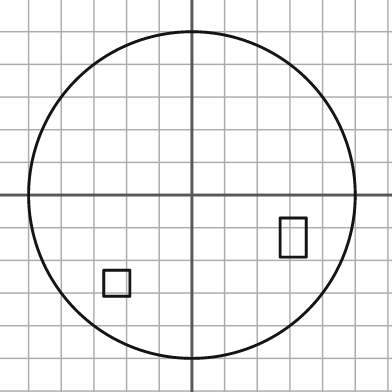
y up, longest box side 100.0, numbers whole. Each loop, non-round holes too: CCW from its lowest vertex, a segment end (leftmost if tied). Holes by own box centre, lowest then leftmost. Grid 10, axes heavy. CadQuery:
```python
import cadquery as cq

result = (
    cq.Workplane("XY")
    .moveTo(0.0, 0.0)
    .circle(50.0)
    .moveTo(-27.0, -31.0)
    .lineTo(-19.0, -31.0)
    .lineTo(-19.0, -23.0)
    .lineTo(-27.0, -23.0)
    .close()
    .moveTo(27.0, -19.0)
    .lineTo(35.0, -19.0)
    .lineTo(35.0, -7.0)
    .lineTo(27.0, -7.0)
    .close()
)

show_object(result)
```